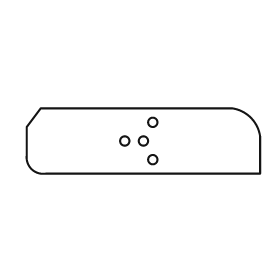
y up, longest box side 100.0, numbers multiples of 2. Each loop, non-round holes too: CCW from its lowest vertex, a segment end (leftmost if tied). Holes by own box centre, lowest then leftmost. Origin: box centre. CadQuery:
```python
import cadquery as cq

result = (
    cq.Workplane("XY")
    .moveTo(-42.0, -14.0)
    .lineTo(50.0, -14.0)
    .lineTo(50.0, 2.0)
    .threePointArc((46.0, 10.0), (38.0, 14.0))
    .lineTo(-44.0, 14.0)
    .lineTo(-50.0, 6.0)
    .lineTo(-50.0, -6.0)
    .threePointArc((-48.0, -12.0), (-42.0, -14.0))
    .close()
    .moveTo(4.0, -8.0)
    .circle(2.0)
    .moveTo(-8.0, 0.0)
    .circle(2.0)
    .moveTo(0.0, 0.0)
    .circle(2.0)
    .moveTo(4.0, 8.0)
    .circle(2.0)
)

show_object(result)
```